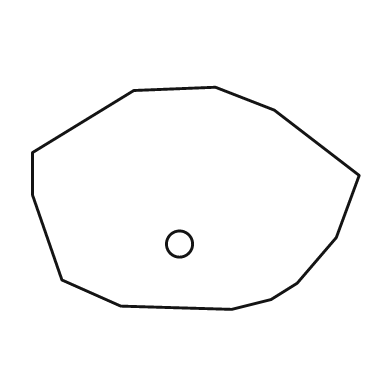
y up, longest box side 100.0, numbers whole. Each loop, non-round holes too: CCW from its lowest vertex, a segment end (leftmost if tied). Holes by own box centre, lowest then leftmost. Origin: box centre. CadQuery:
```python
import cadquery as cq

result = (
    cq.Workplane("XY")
    .moveTo(11.0, -34.0)
    .lineTo(23.0, -31.0)
    .lineTo(31.0, -26.0)
    .lineTo(43.0, -12.0)
    .lineTo(50.0, 7.0)
    .lineTo(24.0, 27.0)
    .lineTo(6.0, 34.0)
    .lineTo(-19.0, 33.0)
    .lineTo(-50.0, 14.0)
    .lineTo(-50.0, 1.0)
    .lineTo(-41.0, -25.0)
    .lineTo(-23.0, -33.0)
    .close()
    .moveTo(-5.0, -14.0)
    .circle(4.0)
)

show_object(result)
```